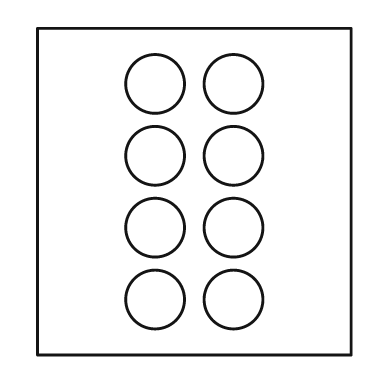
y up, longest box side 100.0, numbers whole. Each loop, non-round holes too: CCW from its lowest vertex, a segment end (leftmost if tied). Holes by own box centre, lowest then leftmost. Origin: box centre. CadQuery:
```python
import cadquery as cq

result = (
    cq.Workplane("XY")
    .moveTo(-48.0, -50.0)
    .lineTo(48.0, -50.0)
    .lineTo(48.0, 50.0)
    .lineTo(-48.0, 50.0)
    .close()
    .moveTo(-12.0, -33.0)
    .circle(9.0)
    .moveTo(12.0, -33.0)
    .circle(9.0)
    .moveTo(-12.0, -11.0)
    .circle(9.0)
    .moveTo(12.0, -11.0)
    .circle(9.0)
    .moveTo(-12.0, 11.0)
    .circle(9.0)
    .moveTo(12.0, 11.0)
    .circle(9.0)
    .moveTo(-12.0, 33.0)
    .circle(9.0)
    .moveTo(12.0, 33.0)
    .circle(9.0)
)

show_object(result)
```